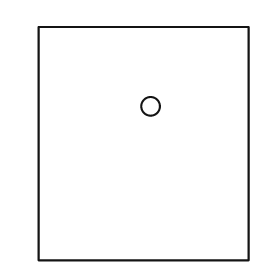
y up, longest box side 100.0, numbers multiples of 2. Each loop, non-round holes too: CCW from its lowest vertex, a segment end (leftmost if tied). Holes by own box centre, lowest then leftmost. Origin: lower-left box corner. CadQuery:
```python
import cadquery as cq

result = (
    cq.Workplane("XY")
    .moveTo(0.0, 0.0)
    .lineTo(90.0, 0.0)
    .lineTo(90.0, 100.0)
    .lineTo(0.0, 100.0)
    .close()
    .moveTo(48.0, 66.0)
    .circle(4.0)
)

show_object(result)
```